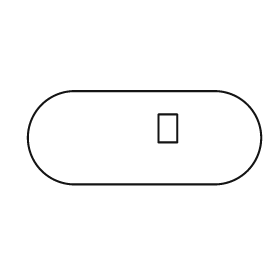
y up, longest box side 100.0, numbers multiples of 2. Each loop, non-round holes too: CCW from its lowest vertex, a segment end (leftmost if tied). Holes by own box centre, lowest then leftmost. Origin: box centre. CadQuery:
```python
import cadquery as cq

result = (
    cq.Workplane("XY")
    .moveTo(-30.0, -20.0)
    .lineTo(30.0, -20.0)
    .threePointArc((50.0, 0.0), (30.0, 20.0))
    .lineTo(-30.0, 20.0)
    .threePointArc((-50.0, 0.0), (-30.0, -20.0))
    .close()
    .moveTo(6.0, -2.0)
    .lineTo(14.0, -2.0)
    .lineTo(14.0, 10.0)
    .lineTo(6.0, 10.0)
    .close()
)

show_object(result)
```